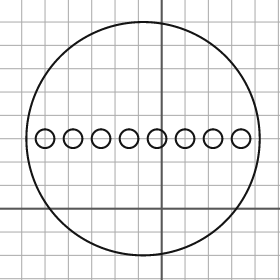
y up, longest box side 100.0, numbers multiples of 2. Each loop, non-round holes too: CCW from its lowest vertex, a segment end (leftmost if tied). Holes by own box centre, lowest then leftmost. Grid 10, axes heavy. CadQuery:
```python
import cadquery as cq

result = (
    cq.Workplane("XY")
    .moveTo(-8.0, 30.0)
    .circle(50.0)
    .moveTo(-50.0, 30.0)
    .circle(4.0)
    .moveTo(-38.0, 30.0)
    .circle(4.0)
    .moveTo(-26.0, 30.0)
    .circle(4.0)
    .moveTo(-14.0, 30.0)
    .circle(4.0)
    .moveTo(-2.0, 30.0)
    .circle(4.0)
    .moveTo(10.0, 30.0)
    .circle(4.0)
    .moveTo(22.0, 30.0)
    .circle(4.0)
    .moveTo(34.0, 30.0)
    .circle(4.0)
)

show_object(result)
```